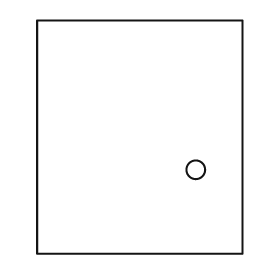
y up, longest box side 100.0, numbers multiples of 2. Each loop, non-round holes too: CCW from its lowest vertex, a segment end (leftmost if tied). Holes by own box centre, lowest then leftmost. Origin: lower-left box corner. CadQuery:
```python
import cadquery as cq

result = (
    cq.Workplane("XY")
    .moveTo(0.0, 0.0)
    .lineTo(88.0, 0.0)
    .lineTo(88.0, 100.0)
    .lineTo(0.0, 100.0)
    .close()
    .moveTo(68.0, 36.0)
    .circle(4.0)
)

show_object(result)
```